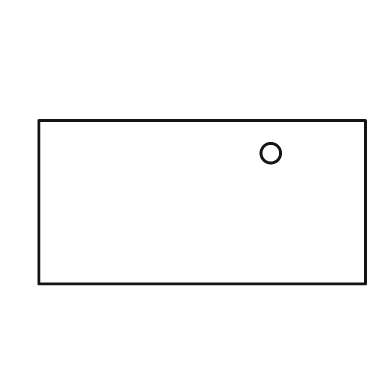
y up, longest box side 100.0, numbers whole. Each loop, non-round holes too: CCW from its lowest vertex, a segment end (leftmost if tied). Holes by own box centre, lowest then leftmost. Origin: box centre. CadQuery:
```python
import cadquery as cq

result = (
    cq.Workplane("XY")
    .moveTo(-50.0, -25.0)
    .lineTo(50.0, -25.0)
    .lineTo(50.0, 25.0)
    .lineTo(-50.0, 25.0)
    .close()
    .moveTo(21.0, 15.0)
    .circle(3.0)
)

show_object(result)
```